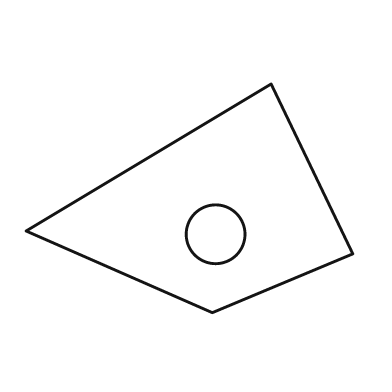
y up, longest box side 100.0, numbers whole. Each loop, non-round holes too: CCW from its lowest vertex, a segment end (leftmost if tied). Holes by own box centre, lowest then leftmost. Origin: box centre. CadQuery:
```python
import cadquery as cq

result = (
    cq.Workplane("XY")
    .moveTo(7.0, -35.0)
    .lineTo(50.0, -17.0)
    .lineTo(25.0, 35.0)
    .lineTo(-50.0, -10.0)
    .close()
    .moveTo(8.0, -11.0)
    .circle(9.0)
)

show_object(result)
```